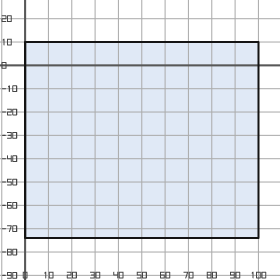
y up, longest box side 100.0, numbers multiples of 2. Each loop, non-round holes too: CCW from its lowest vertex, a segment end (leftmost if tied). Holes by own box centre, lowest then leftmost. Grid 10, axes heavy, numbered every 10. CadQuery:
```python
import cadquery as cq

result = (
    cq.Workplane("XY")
    .moveTo(0.0, -74.0)
    .lineTo(100.0, -74.0)
    .lineTo(100.0, 10.0)
    .lineTo(0.0, 10.0)
    .close()
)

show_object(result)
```